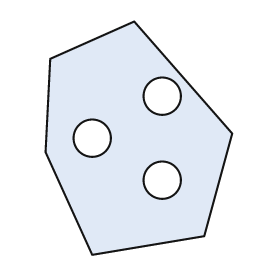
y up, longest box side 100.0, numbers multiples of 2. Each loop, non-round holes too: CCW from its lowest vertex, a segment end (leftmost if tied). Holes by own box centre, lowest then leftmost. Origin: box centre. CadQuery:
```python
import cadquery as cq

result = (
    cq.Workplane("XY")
    .moveTo(-20.0, -50.0)
    .lineTo(28.0, -42.0)
    .lineTo(40.0, 2.0)
    .lineTo(-2.0, 50.0)
    .lineTo(-38.0, 34.0)
    .lineTo(-40.0, -6.0)
    .close()
    .moveTo(10.0, -18.0)
    .circle(8.0)
    .moveTo(-20.0, 0.0)
    .circle(8.0)
    .moveTo(10.0, 18.0)
    .circle(8.0)
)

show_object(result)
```